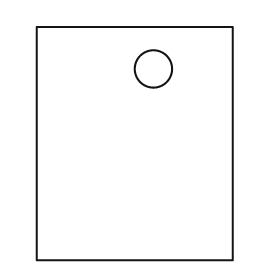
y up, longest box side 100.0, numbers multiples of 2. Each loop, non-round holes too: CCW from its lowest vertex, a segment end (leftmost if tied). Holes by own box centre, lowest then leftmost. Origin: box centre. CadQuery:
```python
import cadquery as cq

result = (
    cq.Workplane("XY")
    .moveTo(-42.0, -50.0)
    .lineTo(42.0, -50.0)
    .lineTo(42.0, 50.0)
    .lineTo(-42.0, 50.0)
    .close()
    .moveTo(8.0, 32.0)
    .circle(8.0)
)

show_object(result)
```